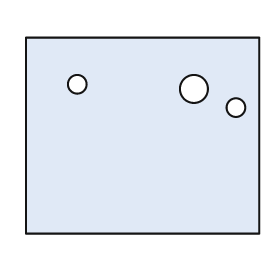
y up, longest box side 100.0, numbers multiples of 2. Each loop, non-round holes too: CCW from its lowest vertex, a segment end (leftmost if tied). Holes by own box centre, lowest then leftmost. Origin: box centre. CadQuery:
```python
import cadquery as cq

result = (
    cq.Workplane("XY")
    .moveTo(-50.0, -42.0)
    .lineTo(50.0, -42.0)
    .lineTo(50.0, 42.0)
    .lineTo(-50.0, 42.0)
    .close()
    .moveTo(40.0, 12.0)
    .circle(4.0)
    .moveTo(22.0, 20.0)
    .circle(6.0)
    .moveTo(-28.0, 22.0)
    .circle(4.0)
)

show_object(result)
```